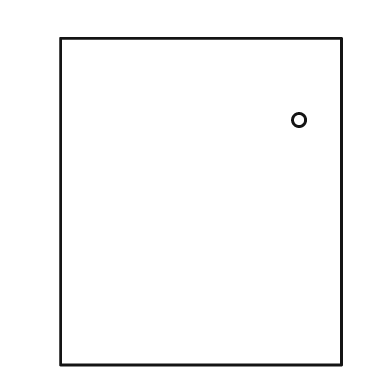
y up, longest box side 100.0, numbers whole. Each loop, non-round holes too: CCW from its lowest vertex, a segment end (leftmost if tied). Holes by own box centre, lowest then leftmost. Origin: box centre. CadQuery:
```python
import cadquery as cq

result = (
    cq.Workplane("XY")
    .moveTo(-43.0, -50.0)
    .lineTo(43.0, -50.0)
    .lineTo(43.0, 50.0)
    .lineTo(-43.0, 50.0)
    .close()
    .moveTo(30.0, 25.0)
    .circle(2.0)
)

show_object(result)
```